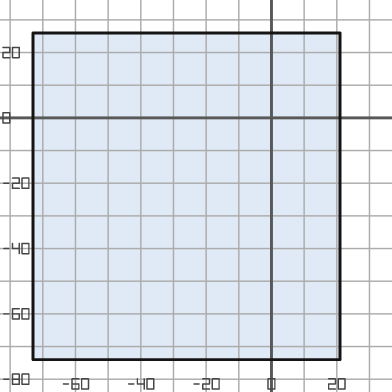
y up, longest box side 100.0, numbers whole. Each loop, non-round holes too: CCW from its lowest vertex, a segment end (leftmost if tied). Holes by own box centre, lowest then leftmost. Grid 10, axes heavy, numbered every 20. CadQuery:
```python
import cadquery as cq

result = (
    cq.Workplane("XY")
    .moveTo(-73.0, -74.0)
    .lineTo(21.0, -74.0)
    .lineTo(21.0, 26.0)
    .lineTo(-73.0, 26.0)
    .close()
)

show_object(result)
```